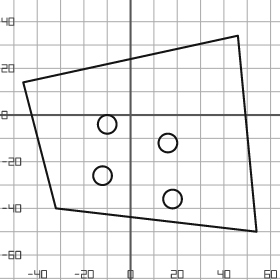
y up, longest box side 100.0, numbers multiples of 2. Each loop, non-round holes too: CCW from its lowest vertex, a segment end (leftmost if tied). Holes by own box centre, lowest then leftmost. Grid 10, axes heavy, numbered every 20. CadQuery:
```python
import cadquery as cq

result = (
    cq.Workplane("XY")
    .moveTo(54.0, -50.0)
    .lineTo(46.0, 34.0)
    .lineTo(-46.0, 14.0)
    .lineTo(-32.0, -40.0)
    .close()
    .moveTo(18.0, -36.0)
    .circle(4.0)
    .moveTo(-12.0, -26.0)
    .circle(4.0)
    .moveTo(16.0, -12.0)
    .circle(4.0)
    .moveTo(-10.0, -4.0)
    .circle(4.0)
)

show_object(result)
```